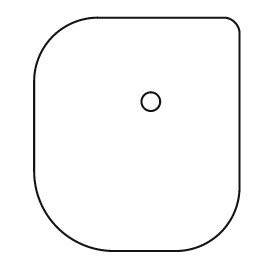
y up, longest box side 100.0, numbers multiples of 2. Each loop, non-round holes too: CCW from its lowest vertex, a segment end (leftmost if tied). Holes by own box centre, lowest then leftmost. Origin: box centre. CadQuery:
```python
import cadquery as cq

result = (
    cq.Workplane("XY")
    .moveTo(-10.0, -50.0)
    .lineTo(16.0, -50.0)
    .threePointArc((36.0, -42.0), (44.0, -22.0))
    .lineTo(44.0, 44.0)
    .threePointArc((42.0, 48.0), (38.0, 50.0))
    .lineTo(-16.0, 50.0)
    .threePointArc((-36.0, 42.0), (-44.0, 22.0))
    .lineTo(-44.0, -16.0)
    .threePointArc((-34.0, -40.0), (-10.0, -50.0))
    .close()
    .moveTo(6.0, 14.0)
    .circle(4.0)
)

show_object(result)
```